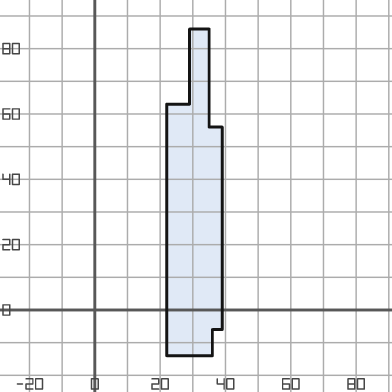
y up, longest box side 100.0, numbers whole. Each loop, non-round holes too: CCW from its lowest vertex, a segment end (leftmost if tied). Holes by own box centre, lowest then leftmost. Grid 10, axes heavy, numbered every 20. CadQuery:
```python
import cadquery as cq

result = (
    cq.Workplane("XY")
    .moveTo(22.0, -14.0)
    .lineTo(36.0, -14.0)
    .lineTo(36.0, -6.0)
    .lineTo(39.0, -6.0)
    .lineTo(39.0, 56.0)
    .lineTo(35.0, 56.0)
    .lineTo(35.0, 86.0)
    .lineTo(29.0, 86.0)
    .lineTo(29.0, 63.0)
    .lineTo(22.0, 63.0)
    .close()
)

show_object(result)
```